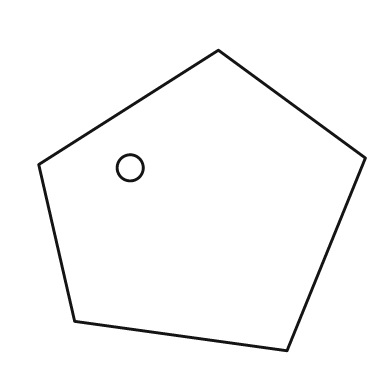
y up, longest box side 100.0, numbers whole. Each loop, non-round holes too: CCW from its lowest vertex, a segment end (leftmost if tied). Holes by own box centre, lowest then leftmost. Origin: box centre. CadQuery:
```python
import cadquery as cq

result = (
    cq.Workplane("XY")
    .moveTo(26.0, -46.0)
    .lineTo(50.0, 13.0)
    .lineTo(5.0, 46.0)
    .lineTo(-50.0, 11.0)
    .lineTo(-39.0, -37.0)
    .close()
    .moveTo(-22.0, 10.0)
    .circle(4.0)
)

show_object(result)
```